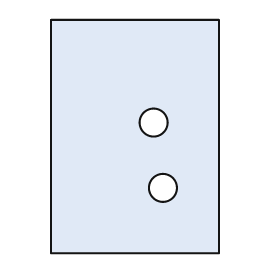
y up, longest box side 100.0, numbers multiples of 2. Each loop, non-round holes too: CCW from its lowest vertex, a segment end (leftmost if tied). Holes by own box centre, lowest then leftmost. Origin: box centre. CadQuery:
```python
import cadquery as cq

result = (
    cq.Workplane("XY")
    .moveTo(-36.0, -50.0)
    .lineTo(36.0, -50.0)
    .lineTo(36.0, 50.0)
    .lineTo(-36.0, 50.0)
    .close()
    .moveTo(12.0, -22.0)
    .circle(6.0)
    .moveTo(8.0, 6.0)
    .circle(6.0)
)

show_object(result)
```